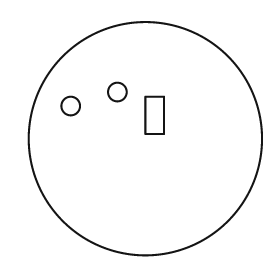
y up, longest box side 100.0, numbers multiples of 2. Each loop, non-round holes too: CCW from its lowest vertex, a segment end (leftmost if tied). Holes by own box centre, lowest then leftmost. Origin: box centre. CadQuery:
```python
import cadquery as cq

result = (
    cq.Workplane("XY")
    .moveTo(0.0, 0.0)
    .circle(50.0)
    .moveTo(0.0, 2.0)
    .lineTo(8.0, 2.0)
    .lineTo(8.0, 18.0)
    .lineTo(0.0, 18.0)
    .close()
    .moveTo(-32.0, 14.0)
    .circle(4.0)
    .moveTo(-12.0, 20.0)
    .circle(4.0)
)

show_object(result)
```